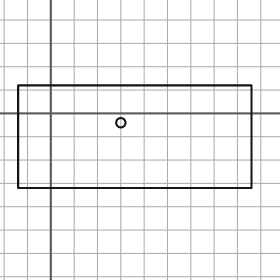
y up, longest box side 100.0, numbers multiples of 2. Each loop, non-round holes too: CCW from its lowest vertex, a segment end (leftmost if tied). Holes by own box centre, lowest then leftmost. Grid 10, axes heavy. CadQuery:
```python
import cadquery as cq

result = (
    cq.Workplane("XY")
    .moveTo(-14.0, -32.0)
    .lineTo(86.0, -32.0)
    .lineTo(86.0, 12.0)
    .lineTo(-14.0, 12.0)
    .close()
    .moveTo(30.0, -4.0)
    .circle(2.0)
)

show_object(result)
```